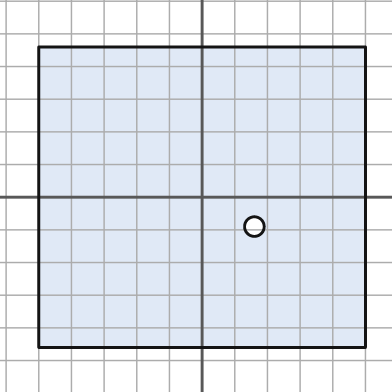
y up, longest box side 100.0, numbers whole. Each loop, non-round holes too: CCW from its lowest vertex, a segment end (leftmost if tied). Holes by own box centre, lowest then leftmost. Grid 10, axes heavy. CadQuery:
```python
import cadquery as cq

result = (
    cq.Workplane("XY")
    .moveTo(-50.0, -46.0)
    .lineTo(50.0, -46.0)
    .lineTo(50.0, 46.0)
    .lineTo(-50.0, 46.0)
    .close()
    .moveTo(16.0, -9.0)
    .circle(3.0)
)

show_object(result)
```